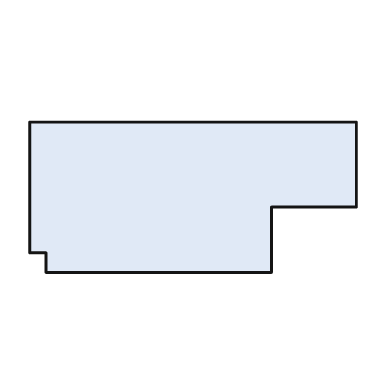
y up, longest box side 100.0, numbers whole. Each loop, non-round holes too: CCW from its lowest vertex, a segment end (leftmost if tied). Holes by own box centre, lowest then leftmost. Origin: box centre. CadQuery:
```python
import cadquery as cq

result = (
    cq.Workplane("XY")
    .moveTo(-45.0, -23.0)
    .lineTo(24.0, -23.0)
    .lineTo(24.0, -3.0)
    .lineTo(50.0, -3.0)
    .lineTo(50.0, 23.0)
    .lineTo(-50.0, 23.0)
    .lineTo(-50.0, -17.0)
    .lineTo(-45.0, -17.0)
    .close()
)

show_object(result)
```